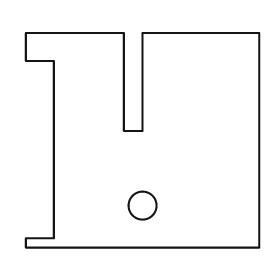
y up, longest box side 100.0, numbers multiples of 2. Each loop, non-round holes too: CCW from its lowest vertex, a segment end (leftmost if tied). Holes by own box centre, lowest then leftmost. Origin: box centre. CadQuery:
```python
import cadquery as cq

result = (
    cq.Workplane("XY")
    .moveTo(-50.0, -46.0)
    .lineTo(50.0, -46.0)
    .lineTo(50.0, 46.0)
    .lineTo(0.0, 46.0)
    .lineTo(0.0, 4.0)
    .lineTo(-8.0, 4.0)
    .lineTo(-8.0, 46.0)
    .lineTo(-50.0, 46.0)
    .lineTo(-50.0, 34.0)
    .lineTo(-38.0, 34.0)
    .lineTo(-38.0, -42.0)
    .lineTo(-50.0, -42.0)
    .close()
    .moveTo(0.0, -28.0)
    .circle(6.0)
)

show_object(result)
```